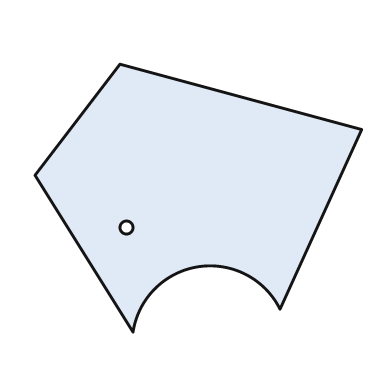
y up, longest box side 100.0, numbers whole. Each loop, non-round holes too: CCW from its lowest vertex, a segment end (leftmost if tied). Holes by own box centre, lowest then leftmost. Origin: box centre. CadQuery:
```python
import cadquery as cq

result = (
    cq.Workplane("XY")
    .moveTo(-20.0, -41.0)
    .threePointArc((0.0, -21.0), (25.0, -34.0))
    .lineTo(50.0, 21.0)
    .lineTo(-24.0, 41.0)
    .lineTo(-50.0, 7.0)
    .close()
    .moveTo(-22.0, -9.0)
    .circle(2.0)
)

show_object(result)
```